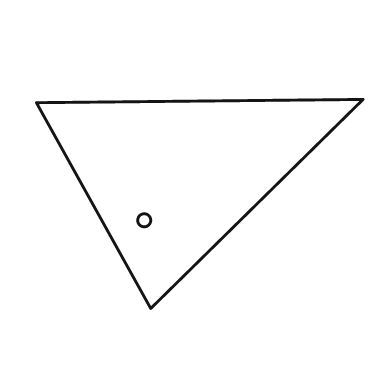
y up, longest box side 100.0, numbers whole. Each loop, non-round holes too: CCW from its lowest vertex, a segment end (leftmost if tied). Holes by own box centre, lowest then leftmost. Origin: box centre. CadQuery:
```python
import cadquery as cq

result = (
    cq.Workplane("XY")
    .moveTo(-15.0, -32.0)
    .lineTo(50.0, 32.0)
    .lineTo(-50.0, 31.0)
    .close()
    .moveTo(-17.0, -5.0)
    .circle(2.0)
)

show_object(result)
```